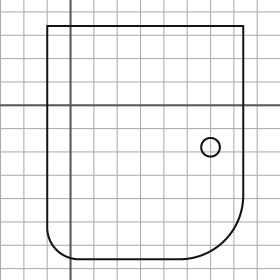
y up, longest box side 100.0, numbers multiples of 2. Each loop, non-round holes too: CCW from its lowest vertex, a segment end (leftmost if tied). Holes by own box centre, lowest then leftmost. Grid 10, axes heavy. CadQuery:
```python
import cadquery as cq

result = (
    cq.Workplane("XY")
    .moveTo(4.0, -66.0)
    .lineTo(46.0, -66.0)
    .threePointArc((66.0, -58.0), (74.0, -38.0))
    .lineTo(74.0, 34.0)
    .lineTo(-10.0, 34.0)
    .lineTo(-10.0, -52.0)
    .threePointArc((-6.0, -62.0), (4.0, -66.0))
    .close()
    .moveTo(60.0, -18.0)
    .circle(4.0)
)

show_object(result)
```